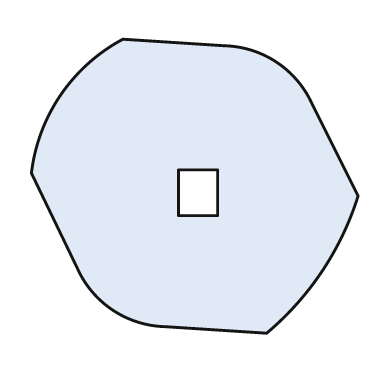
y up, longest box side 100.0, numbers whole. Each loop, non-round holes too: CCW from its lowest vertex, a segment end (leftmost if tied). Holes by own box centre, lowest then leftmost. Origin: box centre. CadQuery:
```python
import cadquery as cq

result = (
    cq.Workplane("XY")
    .moveTo(22.0, -45.0)
    .threePointArc((39.0, -26.0), (50.0, -3.0))
    .lineTo(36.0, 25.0)
    .threePointArc((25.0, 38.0), (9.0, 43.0))
    .lineTo(-22.0, 45.0)
    .threePointArc((-41.0, 28.0), (-50.0, 4.0))
    .lineTo(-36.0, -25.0)
    .threePointArc((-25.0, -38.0), (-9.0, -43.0))
    .close()
    .moveTo(-5.0, -9.0)
    .lineTo(7.0, -9.0)
    .lineTo(7.0, 5.0)
    .lineTo(-5.0, 5.0)
    .close()
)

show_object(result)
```